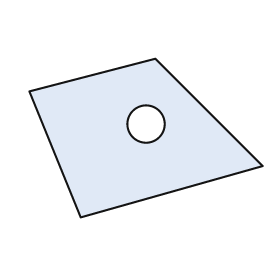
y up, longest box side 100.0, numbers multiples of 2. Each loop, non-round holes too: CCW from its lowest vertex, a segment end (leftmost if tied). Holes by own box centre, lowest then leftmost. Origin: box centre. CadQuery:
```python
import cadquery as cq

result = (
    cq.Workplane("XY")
    .moveTo(-28.0, -34.0)
    .lineTo(50.0, -12.0)
    .lineTo(4.0, 34.0)
    .lineTo(-50.0, 20.0)
    .close()
    .moveTo(0.0, 6.0)
    .circle(8.0)
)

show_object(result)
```